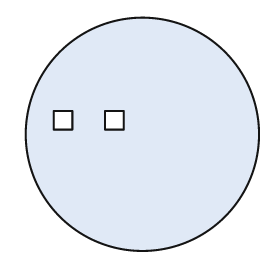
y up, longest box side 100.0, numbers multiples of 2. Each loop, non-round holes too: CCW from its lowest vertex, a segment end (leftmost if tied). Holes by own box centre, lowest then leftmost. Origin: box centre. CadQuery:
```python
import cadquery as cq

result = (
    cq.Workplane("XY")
    .moveTo(0.0, 0.0)
    .circle(50.0)
    .moveTo(-38.0, 2.0)
    .lineTo(-30.0, 2.0)
    .lineTo(-30.0, 10.0)
    .lineTo(-38.0, 10.0)
    .close()
    .moveTo(-16.0, 2.0)
    .lineTo(-8.0, 2.0)
    .lineTo(-8.0, 10.0)
    .lineTo(-16.0, 10.0)
    .close()
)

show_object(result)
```